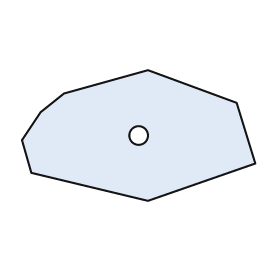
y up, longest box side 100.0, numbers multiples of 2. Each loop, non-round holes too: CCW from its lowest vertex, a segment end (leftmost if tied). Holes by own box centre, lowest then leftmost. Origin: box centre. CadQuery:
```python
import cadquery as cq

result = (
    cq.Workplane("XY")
    .moveTo(4.0, -28.0)
    .lineTo(50.0, -12.0)
    .lineTo(42.0, 14.0)
    .lineTo(4.0, 28.0)
    .lineTo(-32.0, 18.0)
    .lineTo(-42.0, 10.0)
    .lineTo(-50.0, -2.0)
    .lineTo(-46.0, -16.0)
    .close()
    .moveTo(0.0, 0.0)
    .circle(4.0)
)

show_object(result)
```